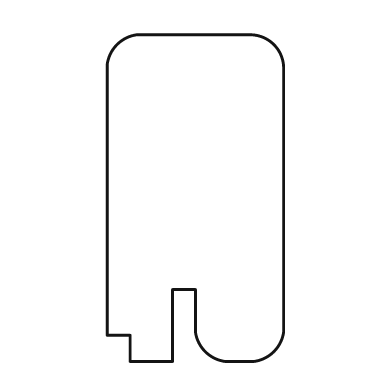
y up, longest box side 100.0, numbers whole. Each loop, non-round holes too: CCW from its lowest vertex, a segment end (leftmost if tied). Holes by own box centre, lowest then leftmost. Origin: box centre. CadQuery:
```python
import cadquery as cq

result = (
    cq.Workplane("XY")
    .moveTo(-20.0, -50.0)
    .lineTo(-7.0, -50.0)
    .lineTo(-7.0, -28.0)
    .lineTo(0.0, -28.0)
    .lineTo(0.0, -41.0)
    .threePointArc((3.0, -47.0), (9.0, -50.0))
    .lineTo(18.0, -50.0)
    .threePointArc((24.0, -47.0), (27.0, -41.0))
    .lineTo(27.0, 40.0)
    .threePointArc((24.0, 47.0), (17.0, 50.0))
    .lineTo(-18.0, 50.0)
    .threePointArc((-24.0, 47.0), (-27.0, 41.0))
    .lineTo(-27.0, -42.0)
    .lineTo(-20.0, -42.0)
    .close()
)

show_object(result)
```